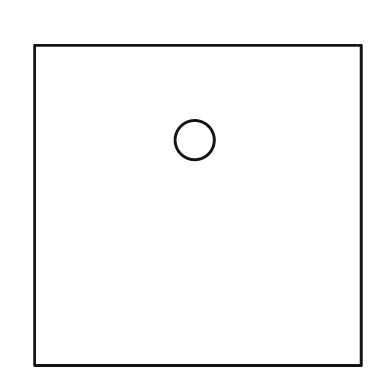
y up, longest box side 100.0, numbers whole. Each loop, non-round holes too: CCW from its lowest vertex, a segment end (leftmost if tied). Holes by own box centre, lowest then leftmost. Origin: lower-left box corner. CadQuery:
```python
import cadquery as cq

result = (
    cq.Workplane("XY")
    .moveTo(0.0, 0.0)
    .lineTo(100.0, 0.0)
    .lineTo(100.0, 98.0)
    .lineTo(0.0, 98.0)
    .close()
    .moveTo(49.0, 69.0)
    .circle(6.0)
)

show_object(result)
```